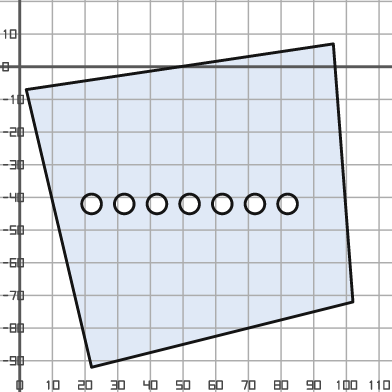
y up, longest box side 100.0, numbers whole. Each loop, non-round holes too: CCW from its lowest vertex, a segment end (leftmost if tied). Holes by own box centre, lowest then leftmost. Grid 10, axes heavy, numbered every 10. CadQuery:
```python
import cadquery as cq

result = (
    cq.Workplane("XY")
    .moveTo(22.0, -92.0)
    .lineTo(102.0, -72.0)
    .lineTo(96.0, 7.0)
    .lineTo(2.0, -7.0)
    .close()
    .moveTo(22.0, -42.0)
    .circle(3.0)
    .moveTo(32.0, -42.0)
    .circle(3.0)
    .moveTo(42.0, -42.0)
    .circle(3.0)
    .moveTo(52.0, -42.0)
    .circle(3.0)
    .moveTo(62.0, -42.0)
    .circle(3.0)
    .moveTo(72.0, -42.0)
    .circle(3.0)
    .moveTo(82.0, -42.0)
    .circle(3.0)
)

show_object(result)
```